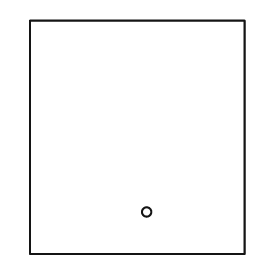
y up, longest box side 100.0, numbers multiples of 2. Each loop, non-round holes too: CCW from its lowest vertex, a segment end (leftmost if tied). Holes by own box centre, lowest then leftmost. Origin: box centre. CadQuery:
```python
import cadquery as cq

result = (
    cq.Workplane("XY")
    .moveTo(-46.0, -50.0)
    .lineTo(46.0, -50.0)
    .lineTo(46.0, 50.0)
    .lineTo(-46.0, 50.0)
    .close()
    .moveTo(4.0, -32.0)
    .circle(2.0)
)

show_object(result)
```